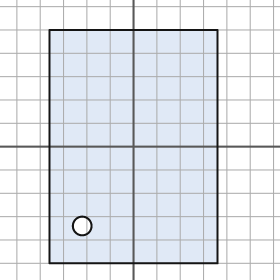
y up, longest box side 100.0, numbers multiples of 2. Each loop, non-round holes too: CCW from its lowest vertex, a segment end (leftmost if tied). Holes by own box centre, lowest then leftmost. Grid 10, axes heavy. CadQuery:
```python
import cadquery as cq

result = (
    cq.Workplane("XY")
    .moveTo(-36.0, -50.0)
    .lineTo(36.0, -50.0)
    .lineTo(36.0, 50.0)
    .lineTo(-36.0, 50.0)
    .close()
    .moveTo(-22.0, -34.0)
    .circle(4.0)
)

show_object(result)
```